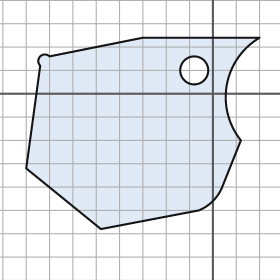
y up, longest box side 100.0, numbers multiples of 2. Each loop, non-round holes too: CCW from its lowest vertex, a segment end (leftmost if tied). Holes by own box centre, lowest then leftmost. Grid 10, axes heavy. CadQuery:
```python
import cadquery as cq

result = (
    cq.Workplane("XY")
    .moveTo(-48.0, -58.0)
    .lineTo(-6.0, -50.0)
    .threePointArc((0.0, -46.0), (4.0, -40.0))
    .lineTo(12.0, -20.0)
    .threePointArc((6.0, 4.0), (20.0, 24.0))
    .lineTo(-30.0, 24.0)
    .lineTo(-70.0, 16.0)
    .threePointArc((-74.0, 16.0), (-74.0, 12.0))
    .lineTo(-80.0, -32.0)
    .close()
    .moveTo(-8.0, 10.0)
    .circle(6.0)
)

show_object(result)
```